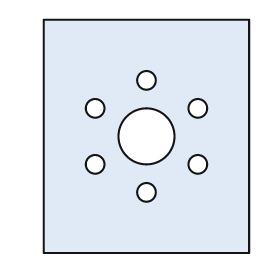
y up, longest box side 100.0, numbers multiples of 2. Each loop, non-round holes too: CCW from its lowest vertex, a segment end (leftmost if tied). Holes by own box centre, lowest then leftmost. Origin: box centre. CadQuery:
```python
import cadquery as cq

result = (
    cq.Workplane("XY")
    .moveTo(-44.0, -50.0)
    .lineTo(44.0, -50.0)
    .lineTo(44.0, 50.0)
    .lineTo(-44.0, 50.0)
    .close()
    .moveTo(0.0, -24.0)
    .circle(4.0)
    .moveTo(-22.0, -12.0)
    .circle(4.0)
    .moveTo(22.0, -12.0)
    .circle(4.0)
    .moveTo(0.0, 0.0)
    .circle(12.0)
    .moveTo(-22.0, 12.0)
    .circle(4.0)
    .moveTo(22.0, 12.0)
    .circle(4.0)
    .moveTo(0.0, 24.0)
    .circle(4.0)
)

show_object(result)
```